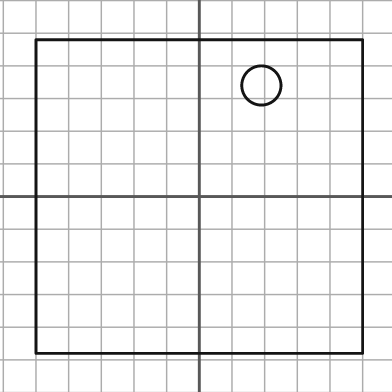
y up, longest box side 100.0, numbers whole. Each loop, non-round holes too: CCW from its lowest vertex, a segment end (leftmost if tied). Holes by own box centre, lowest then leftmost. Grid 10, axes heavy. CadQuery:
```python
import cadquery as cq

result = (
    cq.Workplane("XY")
    .moveTo(-50.0, -48.0)
    .lineTo(50.0, -48.0)
    .lineTo(50.0, 48.0)
    .lineTo(-50.0, 48.0)
    .close()
    .moveTo(19.0, 34.0)
    .circle(6.0)
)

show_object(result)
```